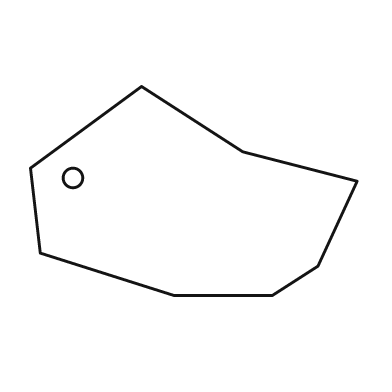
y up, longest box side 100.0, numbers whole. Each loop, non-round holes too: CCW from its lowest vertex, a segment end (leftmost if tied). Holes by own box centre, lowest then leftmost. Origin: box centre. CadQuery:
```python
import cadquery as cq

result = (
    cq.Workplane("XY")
    .moveTo(-6.0, -32.0)
    .lineTo(24.0, -32.0)
    .lineTo(38.0, -23.0)
    .lineTo(50.0, 3.0)
    .lineTo(15.0, 12.0)
    .lineTo(-16.0, 32.0)
    .lineTo(-50.0, 7.0)
    .lineTo(-47.0, -19.0)
    .close()
    .moveTo(-37.0, 4.0)
    .circle(3.0)
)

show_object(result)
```